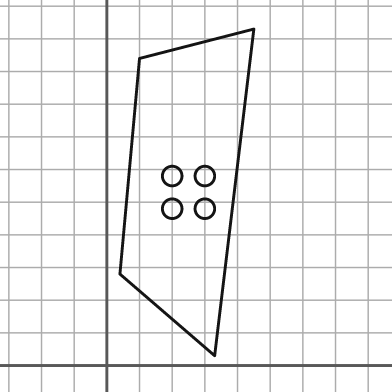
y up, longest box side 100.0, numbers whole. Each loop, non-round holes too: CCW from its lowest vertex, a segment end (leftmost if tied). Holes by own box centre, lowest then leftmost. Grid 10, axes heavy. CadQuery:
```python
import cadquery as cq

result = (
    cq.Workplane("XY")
    .moveTo(33.0, 3.0)
    .lineTo(45.0, 103.0)
    .lineTo(10.0, 94.0)
    .lineTo(4.0, 28.0)
    .close()
    .moveTo(20.0, 48.0)
    .circle(3.0)
    .moveTo(30.0, 48.0)
    .circle(3.0)
    .moveTo(20.0, 58.0)
    .circle(3.0)
    .moveTo(30.0, 58.0)
    .circle(3.0)
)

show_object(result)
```